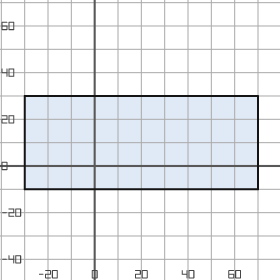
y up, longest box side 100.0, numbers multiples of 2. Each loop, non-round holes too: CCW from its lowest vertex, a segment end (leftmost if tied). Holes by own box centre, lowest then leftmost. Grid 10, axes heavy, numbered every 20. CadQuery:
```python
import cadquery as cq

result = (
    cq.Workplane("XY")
    .moveTo(-30.0, -10.0)
    .lineTo(70.0, -10.0)
    .lineTo(70.0, 30.0)
    .lineTo(-30.0, 30.0)
    .close()
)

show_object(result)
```